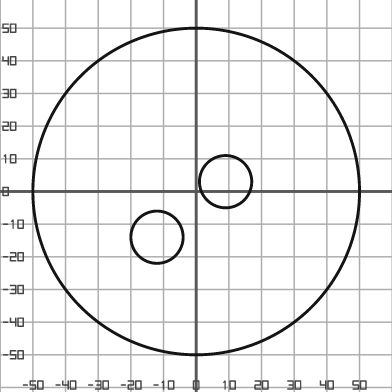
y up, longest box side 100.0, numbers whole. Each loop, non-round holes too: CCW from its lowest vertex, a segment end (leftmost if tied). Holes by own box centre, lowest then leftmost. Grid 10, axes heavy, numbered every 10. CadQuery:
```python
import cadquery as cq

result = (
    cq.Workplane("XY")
    .moveTo(0.0, 0.0)
    .circle(50.0)
    .moveTo(-12.0, -14.0)
    .circle(8.0)
    .moveTo(9.0, 3.0)
    .circle(8.0)
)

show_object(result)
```